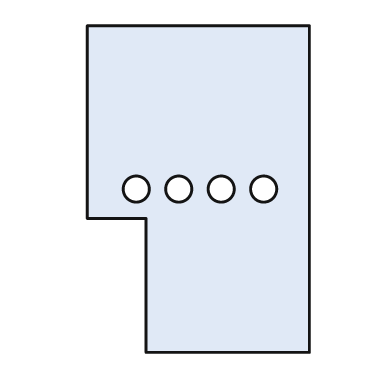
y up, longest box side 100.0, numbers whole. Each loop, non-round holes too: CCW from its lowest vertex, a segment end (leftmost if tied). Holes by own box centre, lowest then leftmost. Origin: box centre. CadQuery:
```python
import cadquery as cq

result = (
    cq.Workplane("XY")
    .moveTo(-16.0, -50.0)
    .lineTo(34.0, -50.0)
    .lineTo(34.0, 50.0)
    .lineTo(-34.0, 50.0)
    .lineTo(-34.0, -9.0)
    .lineTo(-16.0, -9.0)
    .close()
    .moveTo(-19.0, 0.0)
    .circle(4.0)
    .moveTo(-6.0, 0.0)
    .circle(4.0)
    .moveTo(7.0, 0.0)
    .circle(4.0)
    .moveTo(20.0, 0.0)
    .circle(4.0)
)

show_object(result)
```